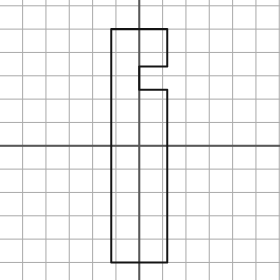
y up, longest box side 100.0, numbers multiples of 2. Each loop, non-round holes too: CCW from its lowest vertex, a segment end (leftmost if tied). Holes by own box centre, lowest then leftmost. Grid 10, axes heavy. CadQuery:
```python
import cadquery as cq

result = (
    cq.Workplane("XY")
    .moveTo(-12.0, -50.0)
    .lineTo(12.0, -50.0)
    .lineTo(12.0, 24.0)
    .lineTo(0.0, 24.0)
    .lineTo(0.0, 34.0)
    .lineTo(12.0, 34.0)
    .lineTo(12.0, 50.0)
    .lineTo(-12.0, 50.0)
    .close()
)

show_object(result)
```